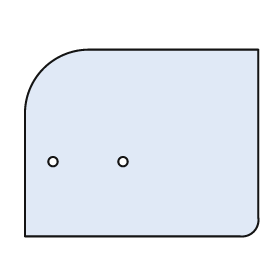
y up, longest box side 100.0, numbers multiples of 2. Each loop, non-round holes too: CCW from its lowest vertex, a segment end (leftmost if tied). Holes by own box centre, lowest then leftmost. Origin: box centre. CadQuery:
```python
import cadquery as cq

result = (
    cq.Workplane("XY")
    .moveTo(-50.0, -40.0)
    .lineTo(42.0, -40.0)
    .threePointArc((48.0, -38.0), (50.0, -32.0))
    .lineTo(50.0, 40.0)
    .lineTo(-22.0, 40.0)
    .threePointArc((-42.0, 32.0), (-50.0, 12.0))
    .close()
    .moveTo(-38.0, -8.0)
    .circle(2.0)
    .moveTo(-8.0, -8.0)
    .circle(2.0)
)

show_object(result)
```